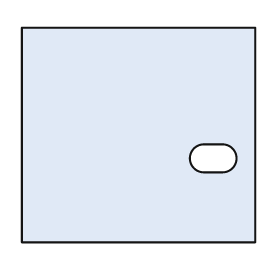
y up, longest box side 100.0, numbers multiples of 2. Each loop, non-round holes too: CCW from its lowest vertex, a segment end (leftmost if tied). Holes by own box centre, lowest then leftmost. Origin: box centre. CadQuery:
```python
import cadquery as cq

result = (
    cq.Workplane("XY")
    .moveTo(-50.0, -46.0)
    .lineTo(50.0, -46.0)
    .lineTo(50.0, 46.0)
    .lineTo(-50.0, 46.0)
    .close()
    .moveTo(28.0, -16.0)
    .lineTo(36.0, -16.0)
    .threePointArc((42.0, -10.0), (36.0, -4.0))
    .lineTo(28.0, -4.0)
    .threePointArc((22.0, -10.0), (28.0, -16.0))
    .close()
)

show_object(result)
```